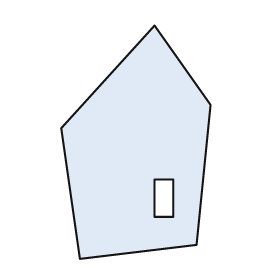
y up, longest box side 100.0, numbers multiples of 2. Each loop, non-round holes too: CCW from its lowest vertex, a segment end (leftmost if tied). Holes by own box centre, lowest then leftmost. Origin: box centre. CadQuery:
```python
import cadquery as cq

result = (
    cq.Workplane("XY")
    .moveTo(-24.0, -50.0)
    .lineTo(26.0, -44.0)
    .lineTo(32.0, 16.0)
    .lineTo(8.0, 50.0)
    .lineTo(-32.0, 6.0)
    .close()
    .moveTo(8.0, -32.0)
    .lineTo(16.0, -32.0)
    .lineTo(16.0, -16.0)
    .lineTo(8.0, -16.0)
    .close()
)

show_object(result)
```